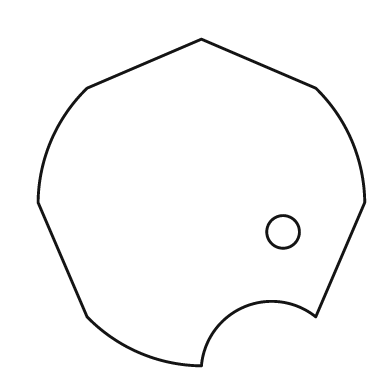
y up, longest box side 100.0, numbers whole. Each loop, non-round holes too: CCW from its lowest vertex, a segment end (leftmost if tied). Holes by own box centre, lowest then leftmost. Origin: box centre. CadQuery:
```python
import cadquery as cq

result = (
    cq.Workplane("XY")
    .moveTo(0.0, -50.0)
    .threePointArc((13.0, -32.0), (35.0, -35.0))
    .lineTo(50.0, 0.0)
    .threePointArc((46.0, 19.0), (35.0, 35.0))
    .lineTo(0.0, 50.0)
    .lineTo(-35.0, 35.0)
    .threePointArc((-46.0, 19.0), (-50.0, 0.0))
    .lineTo(-35.0, -35.0)
    .threePointArc((-19.0, -46.0), (0.0, -50.0))
    .close()
    .moveTo(25.0, -9.0)
    .circle(5.0)
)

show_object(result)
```